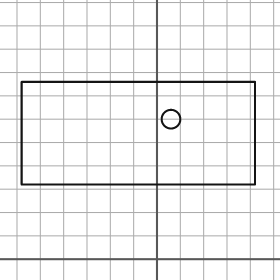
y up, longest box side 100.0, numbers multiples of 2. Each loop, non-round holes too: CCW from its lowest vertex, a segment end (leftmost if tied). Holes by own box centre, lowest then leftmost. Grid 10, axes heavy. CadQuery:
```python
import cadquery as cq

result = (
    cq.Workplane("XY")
    .moveTo(-58.0, 32.0)
    .lineTo(42.0, 32.0)
    .lineTo(42.0, 76.0)
    .lineTo(-58.0, 76.0)
    .close()
    .moveTo(6.0, 60.0)
    .circle(4.0)
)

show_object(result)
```